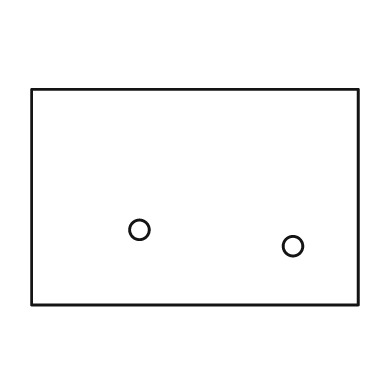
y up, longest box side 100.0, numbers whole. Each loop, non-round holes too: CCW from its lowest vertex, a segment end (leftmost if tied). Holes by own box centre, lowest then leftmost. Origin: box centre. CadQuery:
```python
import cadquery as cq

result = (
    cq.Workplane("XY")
    .moveTo(-50.0, -33.0)
    .lineTo(50.0, -33.0)
    .lineTo(50.0, 33.0)
    .lineTo(-50.0, 33.0)
    .close()
    .moveTo(30.0, -15.0)
    .circle(3.0)
    .moveTo(-17.0, -10.0)
    .circle(3.0)
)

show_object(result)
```